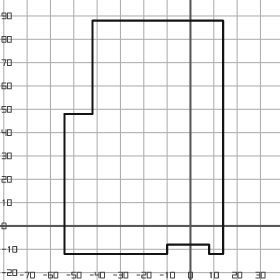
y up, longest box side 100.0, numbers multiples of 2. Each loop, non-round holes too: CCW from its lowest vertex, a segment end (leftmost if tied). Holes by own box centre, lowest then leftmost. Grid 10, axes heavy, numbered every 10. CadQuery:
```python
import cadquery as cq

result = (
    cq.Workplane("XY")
    .moveTo(-54.0, -12.0)
    .lineTo(-10.0, -12.0)
    .lineTo(-10.0, -8.0)
    .lineTo(8.0, -8.0)
    .lineTo(8.0, -12.0)
    .lineTo(14.0, -12.0)
    .lineTo(14.0, 88.0)
    .lineTo(-42.0, 88.0)
    .lineTo(-42.0, 48.0)
    .lineTo(-54.0, 48.0)
    .close()
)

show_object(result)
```